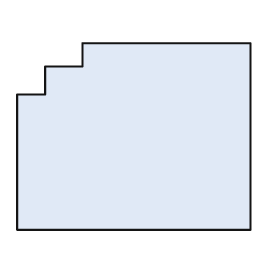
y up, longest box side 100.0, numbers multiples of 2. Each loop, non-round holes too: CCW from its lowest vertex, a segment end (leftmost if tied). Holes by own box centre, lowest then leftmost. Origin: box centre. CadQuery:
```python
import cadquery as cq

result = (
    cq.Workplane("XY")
    .moveTo(-50.0, -40.0)
    .lineTo(50.0, -40.0)
    .lineTo(50.0, 40.0)
    .lineTo(-22.0, 40.0)
    .lineTo(-22.0, 30.0)
    .lineTo(-38.0, 30.0)
    .lineTo(-38.0, 18.0)
    .lineTo(-50.0, 18.0)
    .close()
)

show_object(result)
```